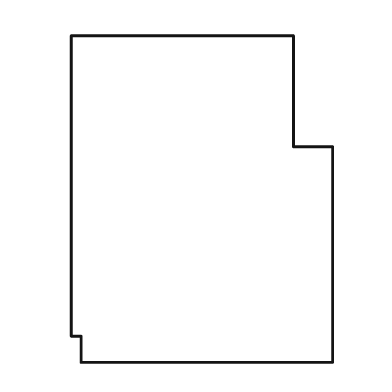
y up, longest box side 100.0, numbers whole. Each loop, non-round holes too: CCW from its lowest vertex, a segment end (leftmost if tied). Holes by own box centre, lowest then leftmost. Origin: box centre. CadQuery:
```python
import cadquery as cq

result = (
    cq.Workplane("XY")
    .moveTo(-37.0, -50.0)
    .lineTo(40.0, -50.0)
    .lineTo(40.0, 16.0)
    .lineTo(28.0, 16.0)
    .lineTo(28.0, 50.0)
    .lineTo(-40.0, 50.0)
    .lineTo(-40.0, -42.0)
    .lineTo(-37.0, -42.0)
    .close()
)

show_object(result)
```